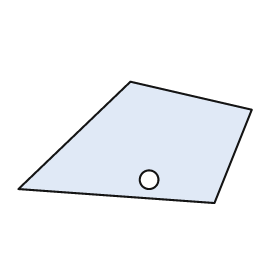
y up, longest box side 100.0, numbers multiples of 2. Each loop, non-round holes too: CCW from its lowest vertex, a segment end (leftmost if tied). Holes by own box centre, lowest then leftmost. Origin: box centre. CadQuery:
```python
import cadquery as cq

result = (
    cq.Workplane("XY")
    .moveTo(34.0, -26.0)
    .lineTo(50.0, 14.0)
    .lineTo(-2.0, 26.0)
    .lineTo(-50.0, -20.0)
    .close()
    .moveTo(6.0, -16.0)
    .circle(4.0)
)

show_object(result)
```